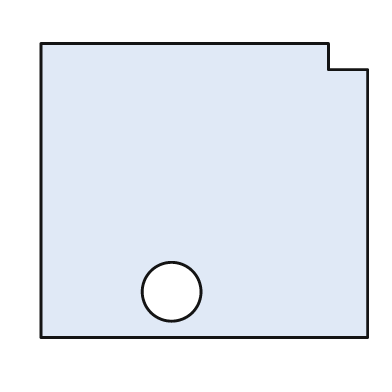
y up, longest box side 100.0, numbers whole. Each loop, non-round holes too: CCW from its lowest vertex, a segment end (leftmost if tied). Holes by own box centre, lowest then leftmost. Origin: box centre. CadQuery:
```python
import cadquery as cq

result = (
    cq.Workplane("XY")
    .moveTo(-50.0, -45.0)
    .lineTo(50.0, -45.0)
    .lineTo(50.0, 37.0)
    .lineTo(38.0, 37.0)
    .lineTo(38.0, 45.0)
    .lineTo(-50.0, 45.0)
    .close()
    .moveTo(-10.0, -31.0)
    .circle(9.0)
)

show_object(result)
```